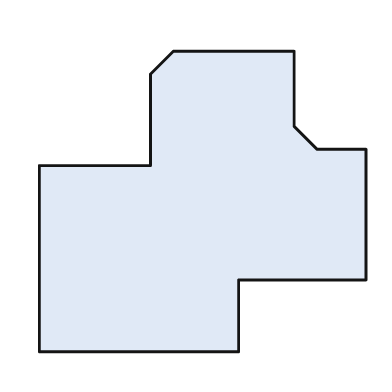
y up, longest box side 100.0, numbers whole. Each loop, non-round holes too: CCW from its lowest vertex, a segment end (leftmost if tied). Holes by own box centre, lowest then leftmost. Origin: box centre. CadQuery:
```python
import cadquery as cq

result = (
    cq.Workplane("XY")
    .moveTo(-50.0, -46.0)
    .lineTo(11.0, -46.0)
    .lineTo(11.0, -24.0)
    .lineTo(50.0, -24.0)
    .lineTo(50.0, 16.0)
    .lineTo(35.0, 16.0)
    .lineTo(28.0, 23.0)
    .lineTo(28.0, 46.0)
    .lineTo(-9.0, 46.0)
    .lineTo(-16.0, 39.0)
    .lineTo(-16.0, 11.0)
    .lineTo(-50.0, 11.0)
    .close()
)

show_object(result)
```